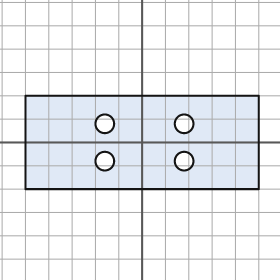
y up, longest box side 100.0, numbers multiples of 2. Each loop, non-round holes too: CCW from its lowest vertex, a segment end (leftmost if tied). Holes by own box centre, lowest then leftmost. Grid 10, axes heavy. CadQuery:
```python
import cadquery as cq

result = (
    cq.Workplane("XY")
    .moveTo(-50.0, -20.0)
    .lineTo(50.0, -20.0)
    .lineTo(50.0, 20.0)
    .lineTo(-50.0, 20.0)
    .close()
    .moveTo(-16.0, -8.0)
    .circle(4.0)
    .moveTo(18.0, -8.0)
    .circle(4.0)
    .moveTo(-16.0, 8.0)
    .circle(4.0)
    .moveTo(18.0, 8.0)
    .circle(4.0)
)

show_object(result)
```